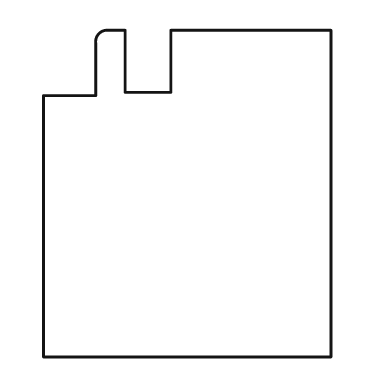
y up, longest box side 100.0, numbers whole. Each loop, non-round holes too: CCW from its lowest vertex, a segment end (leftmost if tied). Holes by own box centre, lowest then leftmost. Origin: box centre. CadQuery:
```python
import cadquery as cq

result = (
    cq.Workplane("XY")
    .moveTo(-44.0, -50.0)
    .lineTo(44.0, -50.0)
    .lineTo(44.0, 50.0)
    .lineTo(-5.0, 50.0)
    .lineTo(-5.0, 31.0)
    .lineTo(-19.0, 31.0)
    .lineTo(-19.0, 50.0)
    .lineTo(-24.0, 50.0)
    .threePointArc((-27.0, 49.0), (-28.0, 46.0))
    .lineTo(-28.0, 30.0)
    .lineTo(-44.0, 30.0)
    .close()
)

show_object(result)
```